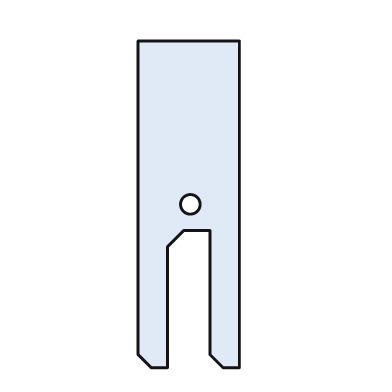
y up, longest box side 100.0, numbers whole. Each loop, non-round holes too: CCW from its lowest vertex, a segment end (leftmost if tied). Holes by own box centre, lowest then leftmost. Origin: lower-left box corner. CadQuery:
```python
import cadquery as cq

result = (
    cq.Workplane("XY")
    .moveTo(4.0, 0.0)
    .lineTo(9.0, 0.0)
    .lineTo(9.0, 37.0)
    .lineTo(14.0, 42.0)
    .lineTo(22.0, 42.0)
    .lineTo(22.0, 4.0)
    .lineTo(26.0, 0.0)
    .lineTo(31.0, 0.0)
    .lineTo(31.0, 100.0)
    .lineTo(0.0, 100.0)
    .lineTo(0.0, 4.0)
    .close()
    .moveTo(16.0, 50.0)
    .circle(3.0)
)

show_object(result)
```